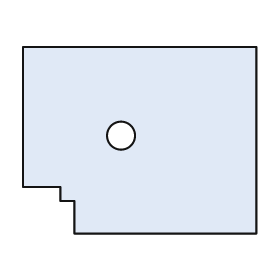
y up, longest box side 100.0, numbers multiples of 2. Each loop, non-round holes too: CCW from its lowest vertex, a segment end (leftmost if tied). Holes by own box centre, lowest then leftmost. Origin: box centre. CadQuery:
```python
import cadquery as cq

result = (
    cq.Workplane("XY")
    .moveTo(-28.0, -40.0)
    .lineTo(50.0, -40.0)
    .lineTo(50.0, 40.0)
    .lineTo(-50.0, 40.0)
    .lineTo(-50.0, -20.0)
    .lineTo(-34.0, -20.0)
    .lineTo(-34.0, -26.0)
    .lineTo(-28.0, -26.0)
    .close()
    .moveTo(-8.0, 2.0)
    .circle(6.0)
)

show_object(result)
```